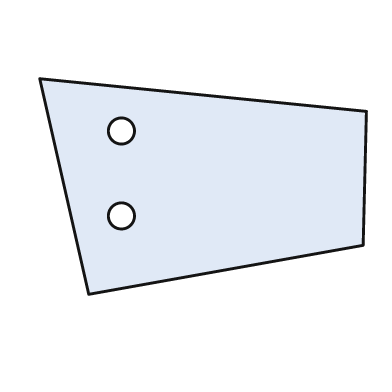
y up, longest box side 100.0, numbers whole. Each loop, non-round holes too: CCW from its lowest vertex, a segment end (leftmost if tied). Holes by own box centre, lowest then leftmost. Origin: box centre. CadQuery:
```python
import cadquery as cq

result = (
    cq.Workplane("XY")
    .moveTo(-35.0, -33.0)
    .lineTo(49.0, -18.0)
    .lineTo(50.0, 23.0)
    .lineTo(-50.0, 33.0)
    .close()
    .moveTo(-25.0, -9.0)
    .circle(4.0)
    .moveTo(-25.0, 17.0)
    .circle(4.0)
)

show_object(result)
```